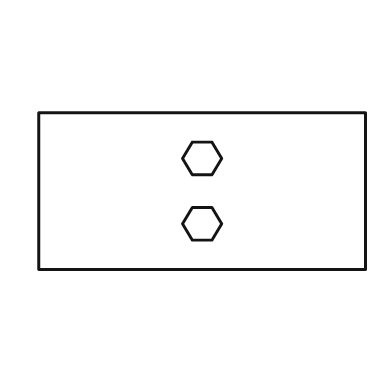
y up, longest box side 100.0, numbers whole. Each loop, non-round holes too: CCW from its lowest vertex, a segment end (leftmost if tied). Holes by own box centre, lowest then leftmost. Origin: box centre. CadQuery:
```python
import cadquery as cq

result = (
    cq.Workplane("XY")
    .moveTo(-50.0, -24.0)
    .lineTo(50.0, -24.0)
    .lineTo(50.0, 24.0)
    .lineTo(-50.0, 24.0)
    .close()
    .moveTo(-3.0, -15.0)
    .lineTo(3.0, -15.0)
    .lineTo(6.0, -10.0)
    .lineTo(3.0, -5.0)
    .lineTo(-3.0, -5.0)
    .lineTo(-6.0, -10.0)
    .close()
    .moveTo(-3.0, 5.0)
    .lineTo(3.0, 5.0)
    .lineTo(6.0, 10.0)
    .lineTo(3.0, 15.0)
    .lineTo(-3.0, 15.0)
    .lineTo(-6.0, 10.0)
    .close()
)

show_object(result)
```